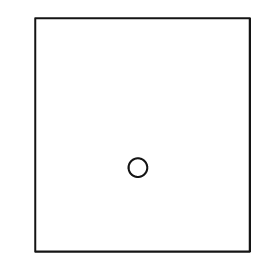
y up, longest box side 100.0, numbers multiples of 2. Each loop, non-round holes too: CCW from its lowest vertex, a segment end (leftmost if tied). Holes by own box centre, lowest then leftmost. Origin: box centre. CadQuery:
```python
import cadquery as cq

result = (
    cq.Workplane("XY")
    .moveTo(-46.0, -50.0)
    .lineTo(46.0, -50.0)
    .lineTo(46.0, 50.0)
    .lineTo(-46.0, 50.0)
    .close()
    .moveTo(-2.0, -14.0)
    .circle(4.0)
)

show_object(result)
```